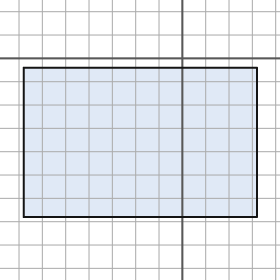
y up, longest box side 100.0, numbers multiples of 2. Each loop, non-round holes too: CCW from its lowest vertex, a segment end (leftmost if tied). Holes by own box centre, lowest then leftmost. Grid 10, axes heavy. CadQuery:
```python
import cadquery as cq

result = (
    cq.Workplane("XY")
    .moveTo(-68.0, -68.0)
    .lineTo(32.0, -68.0)
    .lineTo(32.0, -4.0)
    .lineTo(-68.0, -4.0)
    .close()
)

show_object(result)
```